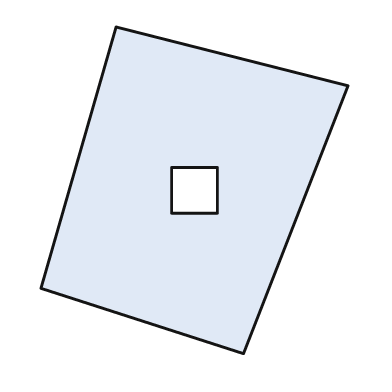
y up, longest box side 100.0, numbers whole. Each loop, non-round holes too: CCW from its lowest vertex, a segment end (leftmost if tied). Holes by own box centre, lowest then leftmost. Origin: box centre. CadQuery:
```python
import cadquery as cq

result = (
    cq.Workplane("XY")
    .moveTo(15.0, -50.0)
    .lineTo(47.0, 32.0)
    .lineTo(-24.0, 50.0)
    .lineTo(-47.0, -30.0)
    .close()
    .moveTo(-7.0, -7.0)
    .lineTo(7.0, -7.0)
    .lineTo(7.0, 7.0)
    .lineTo(-7.0, 7.0)
    .close()
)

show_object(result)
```